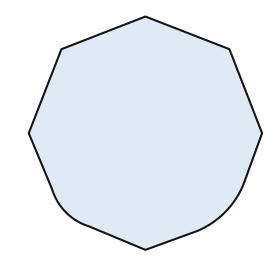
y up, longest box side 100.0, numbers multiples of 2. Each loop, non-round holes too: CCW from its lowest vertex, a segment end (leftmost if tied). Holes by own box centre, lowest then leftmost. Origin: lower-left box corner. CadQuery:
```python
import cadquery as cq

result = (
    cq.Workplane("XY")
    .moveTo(50.0, 0.0)
    .lineTo(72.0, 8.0)
    .threePointArc((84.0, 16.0), (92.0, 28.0))
    .lineTo(100.0, 50.0)
    .lineTo(86.0, 86.0)
    .lineTo(50.0, 100.0)
    .lineTo(14.0, 86.0)
    .lineTo(0.0, 50.0)
    .lineTo(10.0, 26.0)
    .threePointArc((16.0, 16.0), (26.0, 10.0))
    .close()
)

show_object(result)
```